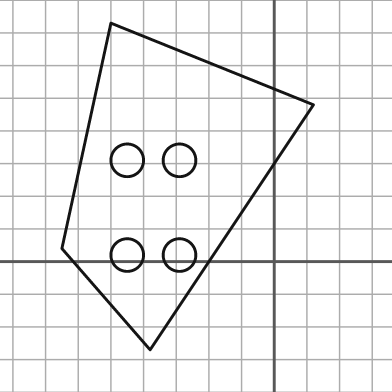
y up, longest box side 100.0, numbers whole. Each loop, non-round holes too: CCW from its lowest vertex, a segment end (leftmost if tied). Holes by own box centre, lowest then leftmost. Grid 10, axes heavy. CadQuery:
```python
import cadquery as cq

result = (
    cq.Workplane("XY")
    .moveTo(-38.0, -27.0)
    .lineTo(12.0, 48.0)
    .lineTo(-50.0, 73.0)
    .lineTo(-65.0, 4.0)
    .close()
    .moveTo(-45.0, 2.0)
    .circle(5.0)
    .moveTo(-29.0, 2.0)
    .circle(5.0)
    .moveTo(-45.0, 31.0)
    .circle(5.0)
    .moveTo(-29.0, 31.0)
    .circle(5.0)
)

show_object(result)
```